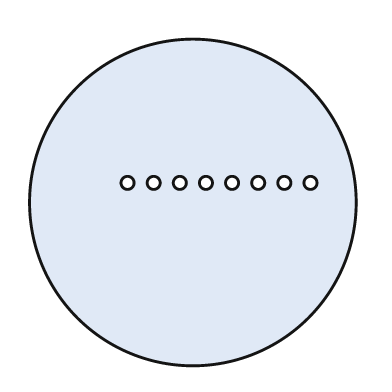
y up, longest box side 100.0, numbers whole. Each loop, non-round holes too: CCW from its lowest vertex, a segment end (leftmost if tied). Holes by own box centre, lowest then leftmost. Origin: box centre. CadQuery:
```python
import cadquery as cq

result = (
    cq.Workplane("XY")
    .moveTo(0.0, 0.0)
    .circle(50.0)
    .moveTo(-20.0, 6.0)
    .circle(2.0)
    .moveTo(-12.0, 6.0)
    .circle(2.0)
    .moveTo(-4.0, 6.0)
    .circle(2.0)
    .moveTo(4.0, 6.0)
    .circle(2.0)
    .moveTo(12.0, 6.0)
    .circle(2.0)
    .moveTo(20.0, 6.0)
    .circle(2.0)
    .moveTo(28.0, 6.0)
    .circle(2.0)
    .moveTo(36.0, 6.0)
    .circle(2.0)
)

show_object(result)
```